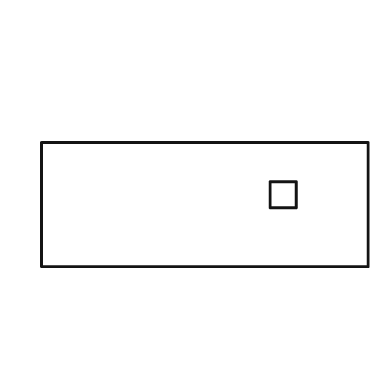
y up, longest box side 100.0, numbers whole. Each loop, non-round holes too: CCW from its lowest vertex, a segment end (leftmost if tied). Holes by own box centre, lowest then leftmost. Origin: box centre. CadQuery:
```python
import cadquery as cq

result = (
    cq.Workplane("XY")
    .moveTo(-50.0, -19.0)
    .lineTo(50.0, -19.0)
    .lineTo(50.0, 19.0)
    .lineTo(-50.0, 19.0)
    .close()
    .moveTo(20.0, -1.0)
    .lineTo(28.0, -1.0)
    .lineTo(28.0, 7.0)
    .lineTo(20.0, 7.0)
    .close()
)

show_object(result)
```